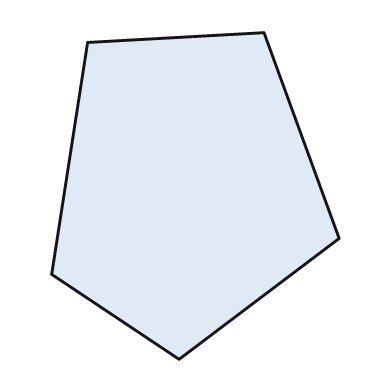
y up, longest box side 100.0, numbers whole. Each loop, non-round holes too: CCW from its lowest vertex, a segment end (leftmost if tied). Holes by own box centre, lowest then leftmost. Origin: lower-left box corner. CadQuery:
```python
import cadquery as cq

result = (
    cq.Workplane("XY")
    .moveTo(39.0, 0.0)
    .lineTo(88.0, 37.0)
    .lineTo(65.0, 100.0)
    .lineTo(11.0, 97.0)
    .lineTo(0.0, 26.0)
    .close()
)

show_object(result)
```